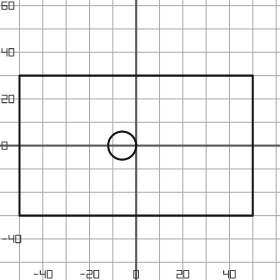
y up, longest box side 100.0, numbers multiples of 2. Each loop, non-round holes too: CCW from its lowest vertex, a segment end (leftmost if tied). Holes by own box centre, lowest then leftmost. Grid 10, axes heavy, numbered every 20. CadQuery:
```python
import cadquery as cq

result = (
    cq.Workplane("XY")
    .moveTo(-50.0, -30.0)
    .lineTo(50.0, -30.0)
    .lineTo(50.0, 30.0)
    .lineTo(-50.0, 30.0)
    .close()
    .moveTo(-6.0, 0.0)
    .circle(6.0)
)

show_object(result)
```